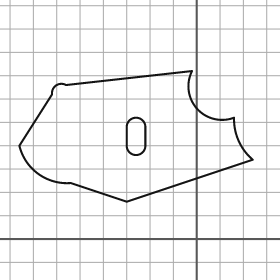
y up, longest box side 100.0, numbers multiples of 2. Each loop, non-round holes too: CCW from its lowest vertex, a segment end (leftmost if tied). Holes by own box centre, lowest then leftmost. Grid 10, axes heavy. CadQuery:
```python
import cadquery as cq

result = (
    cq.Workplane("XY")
    .moveTo(-30.0, 16.0)
    .lineTo(24.0, 34.0)
    .threePointArc((18.0, 42.0), (16.0, 52.0))
    .threePointArc((0.0, 56.0), (-2.0, 72.0))
    .lineTo(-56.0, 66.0)
    .threePointArc((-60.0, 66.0), (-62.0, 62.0))
    .lineTo(-76.0, 40.0)
    .threePointArc((-68.0, 28.0), (-54.0, 24.0))
    .close()
    .moveTo(-30.0, 40.0)
    .threePointArc((-26.0, 36.0), (-22.0, 40.0))
    .lineTo(-22.0, 48.0)
    .threePointArc((-26.0, 52.0), (-30.0, 48.0))
    .close()
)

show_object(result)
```